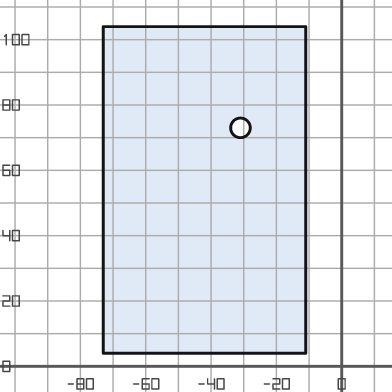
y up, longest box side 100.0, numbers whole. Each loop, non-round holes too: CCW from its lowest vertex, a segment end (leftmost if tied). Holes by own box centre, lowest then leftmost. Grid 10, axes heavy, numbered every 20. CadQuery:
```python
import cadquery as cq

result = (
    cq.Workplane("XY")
    .moveTo(-73.0, 4.0)
    .lineTo(-11.0, 4.0)
    .lineTo(-11.0, 104.0)
    .lineTo(-73.0, 104.0)
    .close()
    .moveTo(-31.0, 73.0)
    .circle(3.0)
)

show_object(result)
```